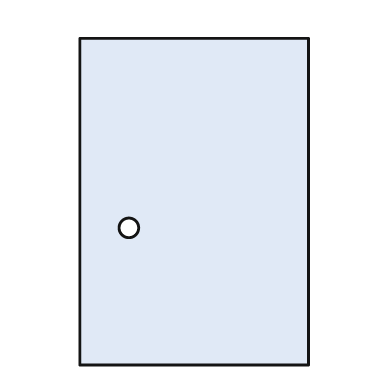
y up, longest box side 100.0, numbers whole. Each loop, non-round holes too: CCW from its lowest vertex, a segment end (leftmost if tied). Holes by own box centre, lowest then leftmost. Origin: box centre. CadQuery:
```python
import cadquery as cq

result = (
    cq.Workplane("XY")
    .moveTo(-35.0, -50.0)
    .lineTo(35.0, -50.0)
    .lineTo(35.0, 50.0)
    .lineTo(-35.0, 50.0)
    .close()
    .moveTo(-20.0, -8.0)
    .circle(3.0)
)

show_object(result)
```